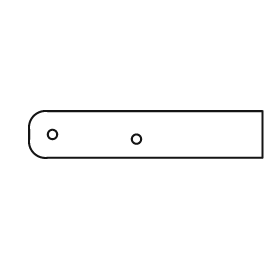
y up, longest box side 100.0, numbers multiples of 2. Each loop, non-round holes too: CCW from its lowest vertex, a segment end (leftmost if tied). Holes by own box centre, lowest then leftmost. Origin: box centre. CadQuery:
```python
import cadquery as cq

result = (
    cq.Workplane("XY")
    .moveTo(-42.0, -10.0)
    .lineTo(50.0, -10.0)
    .lineTo(50.0, 10.0)
    .lineTo(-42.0, 10.0)
    .threePointArc((-48.0, 8.0), (-50.0, 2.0))
    .lineTo(-50.0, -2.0)
    .threePointArc((-48.0, -8.0), (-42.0, -10.0))
    .close()
    .moveTo(-4.0, -2.0)
    .circle(2.0)
    .moveTo(-40.0, 0.0)
    .circle(2.0)
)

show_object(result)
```